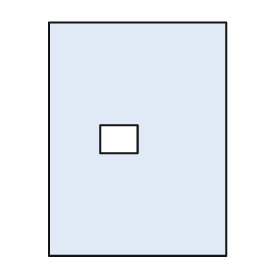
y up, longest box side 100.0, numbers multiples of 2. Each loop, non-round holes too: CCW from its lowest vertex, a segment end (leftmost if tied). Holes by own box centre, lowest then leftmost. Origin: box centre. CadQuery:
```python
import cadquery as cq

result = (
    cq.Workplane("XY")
    .moveTo(-38.0, -50.0)
    .lineTo(38.0, -50.0)
    .lineTo(38.0, 50.0)
    .lineTo(-38.0, 50.0)
    .close()
    .moveTo(-16.0, -6.0)
    .lineTo(0.0, -6.0)
    .lineTo(0.0, 6.0)
    .lineTo(-16.0, 6.0)
    .close()
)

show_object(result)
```